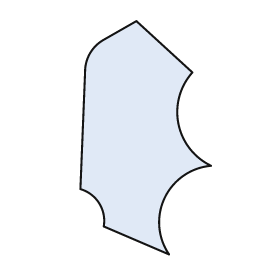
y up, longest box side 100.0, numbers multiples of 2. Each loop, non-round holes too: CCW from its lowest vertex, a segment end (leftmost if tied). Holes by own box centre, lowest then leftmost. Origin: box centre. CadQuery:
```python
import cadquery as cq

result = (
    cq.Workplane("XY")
    .moveTo(10.0, -50.0)
    .threePointArc((8.0, -26.0), (28.0, -12.0))
    .threePointArc((14.0, 6.0), (20.0, 28.0))
    .lineTo(-4.0, 50.0)
    .lineTo(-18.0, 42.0)
    .threePointArc((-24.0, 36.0), (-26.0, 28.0))
    .lineTo(-28.0, -22.0)
    .threePointArc((-20.0, -28.0), (-18.0, -38.0))
    .close()
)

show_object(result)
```